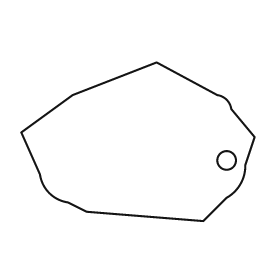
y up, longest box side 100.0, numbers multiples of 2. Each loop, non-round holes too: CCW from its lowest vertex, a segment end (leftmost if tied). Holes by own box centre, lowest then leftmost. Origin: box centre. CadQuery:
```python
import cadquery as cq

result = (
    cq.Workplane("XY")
    .moveTo(28.0, -34.0)
    .lineTo(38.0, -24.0)
    .threePointArc((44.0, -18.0), (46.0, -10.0))
    .lineTo(50.0, 2.0)
    .lineTo(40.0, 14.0)
    .threePointArc((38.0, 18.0), (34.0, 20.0))
    .lineTo(8.0, 34.0)
    .lineTo(-28.0, 20.0)
    .lineTo(-50.0, 4.0)
    .lineTo(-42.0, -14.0)
    .threePointArc((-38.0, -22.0), (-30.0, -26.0))
    .lineTo(-22.0, -30.0)
    .close()
    .moveTo(38.0, -8.0)
    .circle(4.0)
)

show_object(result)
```